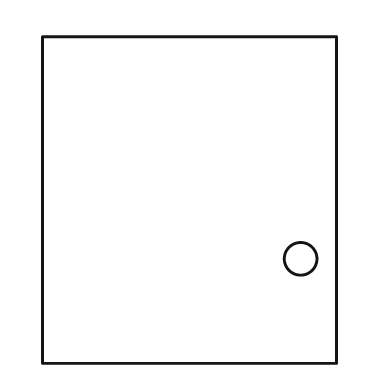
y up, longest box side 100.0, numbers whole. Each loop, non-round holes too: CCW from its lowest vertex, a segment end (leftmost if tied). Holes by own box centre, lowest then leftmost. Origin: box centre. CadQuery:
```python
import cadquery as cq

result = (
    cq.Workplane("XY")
    .moveTo(-45.0, -50.0)
    .lineTo(45.0, -50.0)
    .lineTo(45.0, 50.0)
    .lineTo(-45.0, 50.0)
    .close()
    .moveTo(34.0, -18.0)
    .circle(5.0)
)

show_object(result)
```